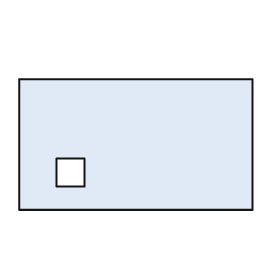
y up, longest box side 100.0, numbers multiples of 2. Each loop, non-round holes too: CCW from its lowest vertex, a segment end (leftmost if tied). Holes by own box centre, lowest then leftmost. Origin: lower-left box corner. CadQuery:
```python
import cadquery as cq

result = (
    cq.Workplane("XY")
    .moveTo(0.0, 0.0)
    .lineTo(100.0, 0.0)
    .lineTo(100.0, 56.0)
    .lineTo(0.0, 56.0)
    .close()
    .moveTo(16.0, 10.0)
    .lineTo(28.0, 10.0)
    .lineTo(28.0, 22.0)
    .lineTo(16.0, 22.0)
    .close()
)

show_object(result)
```